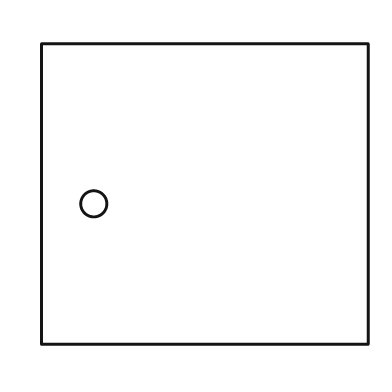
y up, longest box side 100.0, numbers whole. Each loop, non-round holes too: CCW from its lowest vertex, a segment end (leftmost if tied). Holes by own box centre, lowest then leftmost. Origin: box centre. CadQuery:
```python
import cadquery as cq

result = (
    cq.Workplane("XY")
    .moveTo(-50.0, -46.0)
    .lineTo(50.0, -46.0)
    .lineTo(50.0, 46.0)
    .lineTo(-50.0, 46.0)
    .close()
    .moveTo(-34.0, -3.0)
    .circle(4.0)
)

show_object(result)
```